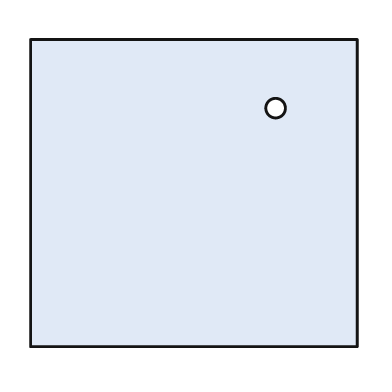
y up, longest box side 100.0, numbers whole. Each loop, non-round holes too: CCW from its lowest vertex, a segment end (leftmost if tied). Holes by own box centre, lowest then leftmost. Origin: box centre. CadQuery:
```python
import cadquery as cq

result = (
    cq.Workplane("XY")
    .moveTo(-50.0, -47.0)
    .lineTo(50.0, -47.0)
    .lineTo(50.0, 47.0)
    .lineTo(-50.0, 47.0)
    .close()
    .moveTo(25.0, 26.0)
    .circle(3.0)
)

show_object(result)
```